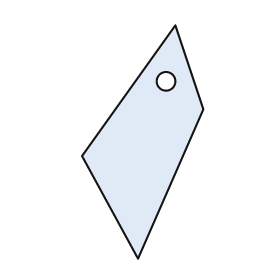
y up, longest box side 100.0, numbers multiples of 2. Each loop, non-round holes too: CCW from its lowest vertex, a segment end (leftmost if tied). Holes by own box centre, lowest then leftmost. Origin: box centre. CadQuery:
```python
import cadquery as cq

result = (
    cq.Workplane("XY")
    .moveTo(-2.0, -50.0)
    .lineTo(26.0, 14.0)
    .lineTo(14.0, 50.0)
    .lineTo(-26.0, -6.0)
    .close()
    .moveTo(10.0, 26.0)
    .circle(4.0)
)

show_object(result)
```